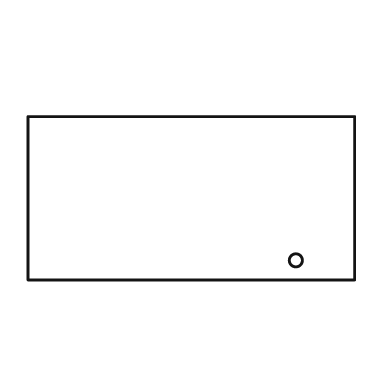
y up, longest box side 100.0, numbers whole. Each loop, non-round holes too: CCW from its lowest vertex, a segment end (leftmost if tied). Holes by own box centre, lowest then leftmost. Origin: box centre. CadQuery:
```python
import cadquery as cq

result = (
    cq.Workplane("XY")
    .moveTo(-50.0, -25.0)
    .lineTo(50.0, -25.0)
    .lineTo(50.0, 25.0)
    .lineTo(-50.0, 25.0)
    .close()
    .moveTo(32.0, -19.0)
    .circle(2.0)
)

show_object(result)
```